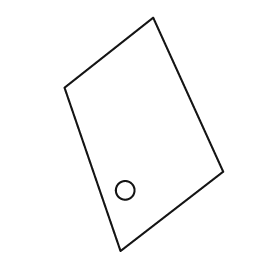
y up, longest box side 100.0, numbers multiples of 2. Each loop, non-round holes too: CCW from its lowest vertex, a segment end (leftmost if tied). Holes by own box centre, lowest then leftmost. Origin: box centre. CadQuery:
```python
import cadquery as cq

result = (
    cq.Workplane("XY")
    .moveTo(-10.0, -50.0)
    .lineTo(34.0, -16.0)
    .lineTo(4.0, 50.0)
    .lineTo(-34.0, 20.0)
    .close()
    .moveTo(-8.0, -24.0)
    .circle(4.0)
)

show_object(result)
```